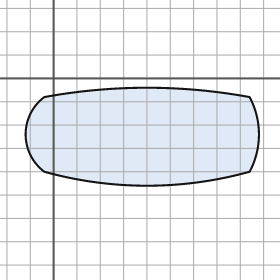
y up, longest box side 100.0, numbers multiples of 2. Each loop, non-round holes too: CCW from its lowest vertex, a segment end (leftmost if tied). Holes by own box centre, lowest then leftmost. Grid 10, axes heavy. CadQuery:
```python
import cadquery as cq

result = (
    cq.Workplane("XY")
    .moveTo(-4.0, -40.0)
    .threePointArc((40.0, -46.0), (84.0, -40.0))
    .threePointArc((88.0, -24.0), (84.0, -8.0))
    .threePointArc((40.0, -4.0), (-4.0, -8.0))
    .threePointArc((-12.0, -24.0), (-4.0, -40.0))
    .close()
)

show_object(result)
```